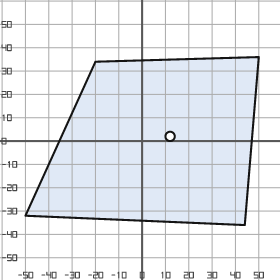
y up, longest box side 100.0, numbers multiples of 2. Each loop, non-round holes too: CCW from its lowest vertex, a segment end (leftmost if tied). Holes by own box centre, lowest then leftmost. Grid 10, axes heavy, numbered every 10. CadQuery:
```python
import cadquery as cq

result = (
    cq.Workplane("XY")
    .moveTo(44.0, -36.0)
    .lineTo(50.0, 36.0)
    .lineTo(-20.0, 34.0)
    .lineTo(-50.0, -32.0)
    .close()
    .moveTo(12.0, 2.0)
    .circle(2.0)
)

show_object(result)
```